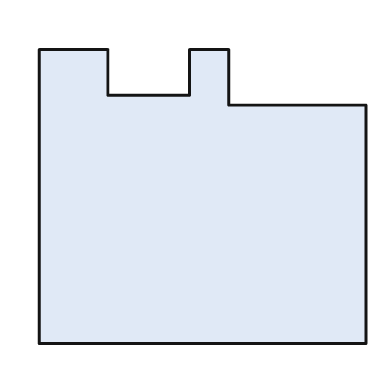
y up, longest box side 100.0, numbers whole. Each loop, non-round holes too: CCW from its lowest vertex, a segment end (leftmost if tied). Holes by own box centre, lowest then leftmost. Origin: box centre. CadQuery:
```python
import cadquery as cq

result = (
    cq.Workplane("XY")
    .moveTo(-50.0, -45.0)
    .lineTo(50.0, -45.0)
    .lineTo(50.0, 28.0)
    .lineTo(8.0, 28.0)
    .lineTo(8.0, 45.0)
    .lineTo(-4.0, 45.0)
    .lineTo(-4.0, 31.0)
    .lineTo(-29.0, 31.0)
    .lineTo(-29.0, 45.0)
    .lineTo(-50.0, 45.0)
    .close()
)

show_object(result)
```